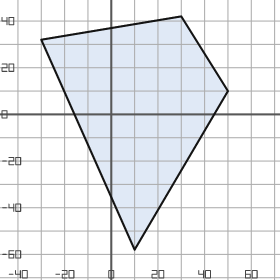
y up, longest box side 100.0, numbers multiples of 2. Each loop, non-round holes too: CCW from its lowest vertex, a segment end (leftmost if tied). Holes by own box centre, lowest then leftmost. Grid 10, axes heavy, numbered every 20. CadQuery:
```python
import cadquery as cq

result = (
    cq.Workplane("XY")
    .moveTo(10.0, -58.0)
    .lineTo(50.0, 10.0)
    .lineTo(30.0, 42.0)
    .lineTo(-30.0, 32.0)
    .close()
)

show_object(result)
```